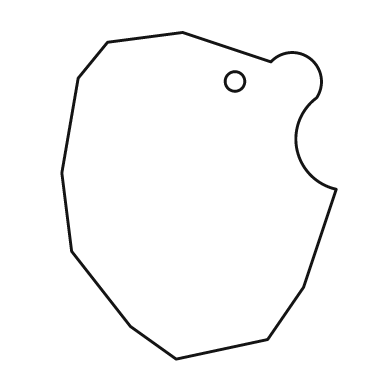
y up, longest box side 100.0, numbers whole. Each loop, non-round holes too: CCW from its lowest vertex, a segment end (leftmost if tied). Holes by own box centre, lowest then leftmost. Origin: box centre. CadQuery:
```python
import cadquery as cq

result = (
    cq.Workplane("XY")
    .moveTo(-7.0, -50.0)
    .lineTo(21.0, -44.0)
    .lineTo(32.0, -28.0)
    .lineTo(42.0, 2.0)
    .threePointArc((30.0, 14.0), (36.0, 30.0))
    .threePointArc((34.0, 42.0), (22.0, 41.0))
    .lineTo(-5.0, 50.0)
    .lineTo(-28.0, 47.0)
    .lineTo(-37.0, 36.0)
    .lineTo(-42.0, 7.0)
    .lineTo(-39.0, -17.0)
    .lineTo(-21.0, -40.0)
    .close()
    .moveTo(11.0, 35.0)
    .circle(3.0)
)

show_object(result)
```